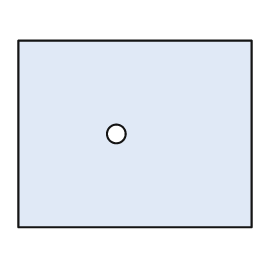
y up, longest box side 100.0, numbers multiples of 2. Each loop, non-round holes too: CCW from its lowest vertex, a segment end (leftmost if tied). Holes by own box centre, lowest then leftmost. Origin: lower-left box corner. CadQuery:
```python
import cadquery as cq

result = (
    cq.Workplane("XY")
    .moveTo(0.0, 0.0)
    .lineTo(100.0, 0.0)
    .lineTo(100.0, 80.0)
    .lineTo(0.0, 80.0)
    .close()
    .moveTo(42.0, 40.0)
    .circle(4.0)
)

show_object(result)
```